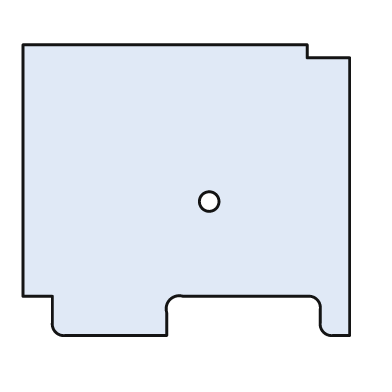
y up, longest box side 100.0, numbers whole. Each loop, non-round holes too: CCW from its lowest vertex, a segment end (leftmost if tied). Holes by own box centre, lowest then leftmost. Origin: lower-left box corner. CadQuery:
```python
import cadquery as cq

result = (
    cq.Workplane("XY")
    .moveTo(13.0, 0.0)
    .lineTo(44.0, 0.0)
    .lineTo(44.0, 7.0)
    .threePointArc((45.0, 11.0), (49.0, 12.0))
    .lineTo(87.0, 12.0)
    .threePointArc((90.0, 11.0), (91.0, 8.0))
    .lineTo(91.0, 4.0)
    .threePointArc((92.0, 1.0), (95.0, 0.0))
    .lineTo(100.0, 0.0)
    .lineTo(100.0, 85.0)
    .lineTo(87.0, 85.0)
    .lineTo(87.0, 89.0)
    .lineTo(0.0, 89.0)
    .lineTo(0.0, 12.0)
    .lineTo(9.0, 12.0)
    .lineTo(9.0, 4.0)
    .threePointArc((10.0, 1.0), (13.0, 0.0))
    .close()
    .moveTo(57.0, 41.0)
    .circle(3.0)
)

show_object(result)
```